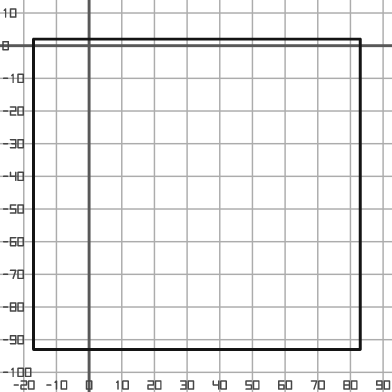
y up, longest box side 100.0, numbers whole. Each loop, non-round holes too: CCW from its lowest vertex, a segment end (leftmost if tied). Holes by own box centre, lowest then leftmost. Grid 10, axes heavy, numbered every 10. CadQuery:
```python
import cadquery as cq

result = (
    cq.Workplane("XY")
    .moveTo(-17.0, -93.0)
    .lineTo(83.0, -93.0)
    .lineTo(83.0, 2.0)
    .lineTo(-17.0, 2.0)
    .close()
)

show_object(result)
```